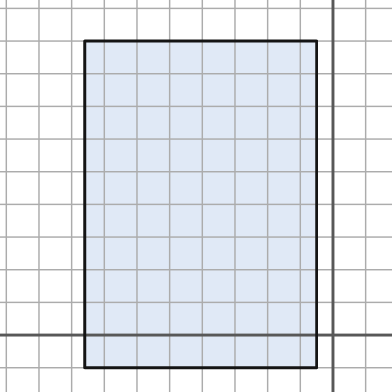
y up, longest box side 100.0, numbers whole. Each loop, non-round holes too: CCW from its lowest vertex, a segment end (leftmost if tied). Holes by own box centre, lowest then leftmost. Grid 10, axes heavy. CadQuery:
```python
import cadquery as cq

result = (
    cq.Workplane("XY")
    .moveTo(-76.0, -10.0)
    .lineTo(-5.0, -10.0)
    .lineTo(-5.0, 90.0)
    .lineTo(-76.0, 90.0)
    .close()
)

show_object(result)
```